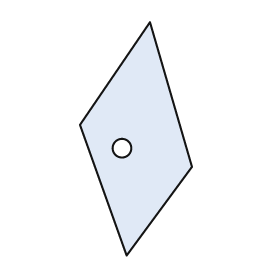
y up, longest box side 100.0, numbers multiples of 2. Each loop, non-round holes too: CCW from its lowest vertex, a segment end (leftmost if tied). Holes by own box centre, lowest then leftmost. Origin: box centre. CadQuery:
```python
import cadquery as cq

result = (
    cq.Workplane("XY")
    .moveTo(-4.0, -50.0)
    .lineTo(24.0, -12.0)
    .lineTo(6.0, 50.0)
    .lineTo(-24.0, 6.0)
    .close()
    .moveTo(-6.0, -4.0)
    .circle(4.0)
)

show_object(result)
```